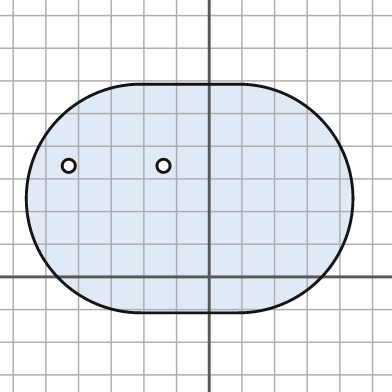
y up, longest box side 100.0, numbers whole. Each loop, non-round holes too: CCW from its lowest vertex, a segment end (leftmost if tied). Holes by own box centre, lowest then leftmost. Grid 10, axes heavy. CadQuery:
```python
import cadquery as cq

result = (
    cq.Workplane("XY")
    .moveTo(-21.0, -11.0)
    .lineTo(9.0, -11.0)
    .threePointArc((44.0, 24.0), (9.0, 59.0))
    .lineTo(-21.0, 59.0)
    .threePointArc((-56.0, 24.0), (-21.0, -11.0))
    .close()
    .moveTo(-43.0, 34.0)
    .circle(2.0)
    .moveTo(-14.0, 34.0)
    .circle(2.0)
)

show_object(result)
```